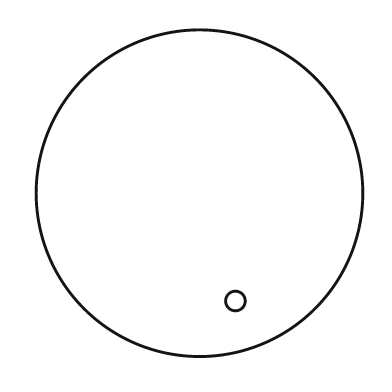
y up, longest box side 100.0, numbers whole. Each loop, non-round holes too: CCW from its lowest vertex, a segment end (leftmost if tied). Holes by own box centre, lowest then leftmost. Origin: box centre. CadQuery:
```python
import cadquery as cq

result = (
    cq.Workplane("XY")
    .moveTo(0.0, 0.0)
    .circle(50.0)
    .moveTo(11.0, -33.0)
    .circle(3.0)
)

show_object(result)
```